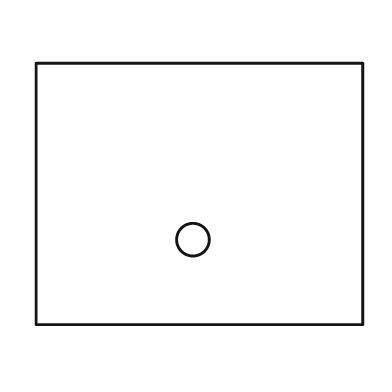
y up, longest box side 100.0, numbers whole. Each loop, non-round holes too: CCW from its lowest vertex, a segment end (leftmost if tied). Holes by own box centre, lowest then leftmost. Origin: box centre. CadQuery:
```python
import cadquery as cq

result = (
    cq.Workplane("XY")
    .moveTo(-50.0, -40.0)
    .lineTo(50.0, -40.0)
    .lineTo(50.0, 40.0)
    .lineTo(-50.0, 40.0)
    .close()
    .moveTo(-2.0, -14.0)
    .circle(5.0)
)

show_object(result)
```